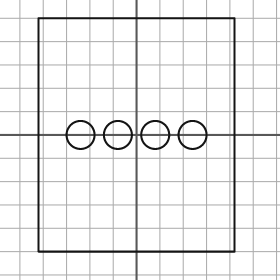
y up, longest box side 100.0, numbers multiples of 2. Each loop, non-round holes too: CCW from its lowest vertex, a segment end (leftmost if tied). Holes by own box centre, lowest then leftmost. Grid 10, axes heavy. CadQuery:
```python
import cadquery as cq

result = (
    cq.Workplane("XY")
    .moveTo(-42.0, -50.0)
    .lineTo(42.0, -50.0)
    .lineTo(42.0, 50.0)
    .lineTo(-42.0, 50.0)
    .close()
    .moveTo(-24.0, 0.0)
    .circle(6.0)
    .moveTo(-8.0, 0.0)
    .circle(6.0)
    .moveTo(8.0, 0.0)
    .circle(6.0)
    .moveTo(24.0, 0.0)
    .circle(6.0)
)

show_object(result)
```